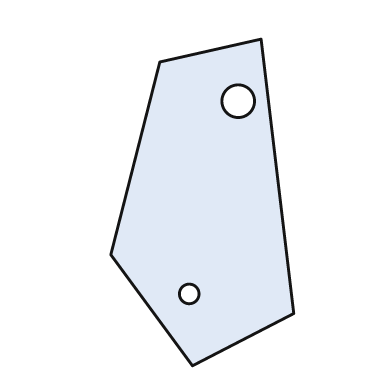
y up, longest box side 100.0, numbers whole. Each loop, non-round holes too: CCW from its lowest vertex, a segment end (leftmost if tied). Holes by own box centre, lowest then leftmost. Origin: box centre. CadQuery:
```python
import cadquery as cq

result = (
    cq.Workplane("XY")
    .moveTo(-3.0, -50.0)
    .lineTo(28.0, -34.0)
    .lineTo(18.0, 50.0)
    .lineTo(-13.0, 43.0)
    .lineTo(-28.0, -16.0)
    .close()
    .moveTo(-4.0, -28.0)
    .circle(3.0)
    .moveTo(11.0, 31.0)
    .circle(5.0)
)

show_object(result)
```